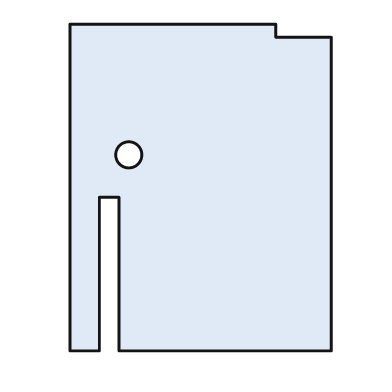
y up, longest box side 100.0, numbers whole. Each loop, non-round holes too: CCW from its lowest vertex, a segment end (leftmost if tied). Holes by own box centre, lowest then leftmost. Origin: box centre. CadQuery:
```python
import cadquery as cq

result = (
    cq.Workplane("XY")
    .moveTo(-40.0, -50.0)
    .lineTo(-31.0, -50.0)
    .lineTo(-31.0, -3.0)
    .lineTo(-25.0, -3.0)
    .lineTo(-25.0, -50.0)
    .lineTo(40.0, -50.0)
    .lineTo(40.0, 46.0)
    .lineTo(23.0, 46.0)
    .lineTo(23.0, 50.0)
    .lineTo(-40.0, 50.0)
    .close()
    .moveTo(-22.0, 10.0)
    .circle(4.0)
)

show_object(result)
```